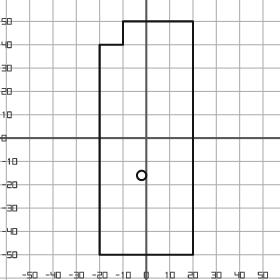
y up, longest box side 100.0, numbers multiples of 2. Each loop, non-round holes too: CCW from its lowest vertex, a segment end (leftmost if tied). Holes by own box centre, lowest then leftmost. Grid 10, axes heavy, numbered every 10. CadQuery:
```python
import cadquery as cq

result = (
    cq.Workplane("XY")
    .moveTo(-20.0, -50.0)
    .lineTo(20.0, -50.0)
    .lineTo(20.0, 50.0)
    .lineTo(-10.0, 50.0)
    .lineTo(-10.0, 40.0)
    .lineTo(-20.0, 40.0)
    .close()
    .moveTo(-2.0, -16.0)
    .circle(2.0)
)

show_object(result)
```